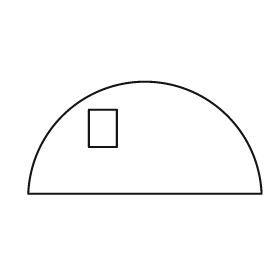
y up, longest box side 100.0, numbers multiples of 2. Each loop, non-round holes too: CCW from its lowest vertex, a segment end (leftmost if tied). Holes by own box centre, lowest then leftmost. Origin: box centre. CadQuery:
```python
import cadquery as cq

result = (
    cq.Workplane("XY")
    .moveTo(-50.0, -24.0)
    .lineTo(50.0, -24.0)
    .threePointArc((0.0, 24.0), (-50.0, -24.0))
    .close()
    .moveTo(-24.0, -4.0)
    .lineTo(-12.0, -4.0)
    .lineTo(-12.0, 12.0)
    .lineTo(-24.0, 12.0)
    .close()
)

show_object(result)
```